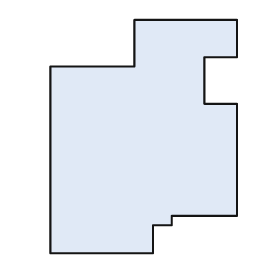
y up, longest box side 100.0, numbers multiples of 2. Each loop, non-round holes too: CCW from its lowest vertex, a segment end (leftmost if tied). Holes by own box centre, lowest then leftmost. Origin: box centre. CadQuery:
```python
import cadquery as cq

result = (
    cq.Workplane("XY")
    .moveTo(-40.0, -50.0)
    .lineTo(4.0, -50.0)
    .lineTo(4.0, -38.0)
    .lineTo(12.0, -38.0)
    .lineTo(12.0, -34.0)
    .lineTo(40.0, -34.0)
    .lineTo(40.0, 14.0)
    .lineTo(26.0, 14.0)
    .lineTo(26.0, 34.0)
    .lineTo(40.0, 34.0)
    .lineTo(40.0, 50.0)
    .lineTo(-4.0, 50.0)
    .lineTo(-4.0, 30.0)
    .lineTo(-40.0, 30.0)
    .close()
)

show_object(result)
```